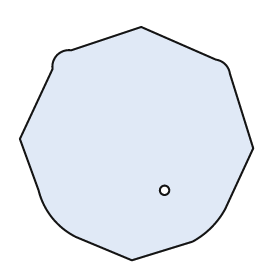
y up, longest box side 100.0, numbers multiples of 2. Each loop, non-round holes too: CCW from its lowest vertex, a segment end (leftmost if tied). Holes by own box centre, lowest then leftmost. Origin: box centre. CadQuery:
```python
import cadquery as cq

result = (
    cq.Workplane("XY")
    .moveTo(-2.0, -50.0)
    .lineTo(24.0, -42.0)
    .threePointArc((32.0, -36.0), (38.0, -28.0))
    .lineTo(50.0, -2.0)
    .lineTo(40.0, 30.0)
    .threePointArc((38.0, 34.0), (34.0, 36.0))
    .lineTo(2.0, 50.0)
    .lineTo(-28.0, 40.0)
    .threePointArc((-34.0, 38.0), (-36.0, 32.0))
    .lineTo(-50.0, 2.0)
    .lineTo(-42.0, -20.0)
    .threePointArc((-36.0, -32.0), (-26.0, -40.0))
    .close()
    .moveTo(12.0, -20.0)
    .circle(2.0)
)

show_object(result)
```